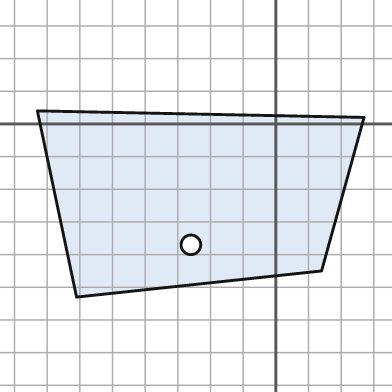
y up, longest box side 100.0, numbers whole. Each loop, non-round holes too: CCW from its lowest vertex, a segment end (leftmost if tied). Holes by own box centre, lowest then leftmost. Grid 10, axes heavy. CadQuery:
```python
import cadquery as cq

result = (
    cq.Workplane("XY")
    .moveTo(-61.0, -53.0)
    .lineTo(14.0, -45.0)
    .lineTo(27.0, 2.0)
    .lineTo(-73.0, 4.0)
    .close()
    .moveTo(-26.0, -37.0)
    .circle(3.0)
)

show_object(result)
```